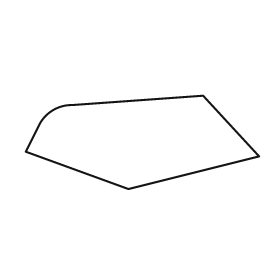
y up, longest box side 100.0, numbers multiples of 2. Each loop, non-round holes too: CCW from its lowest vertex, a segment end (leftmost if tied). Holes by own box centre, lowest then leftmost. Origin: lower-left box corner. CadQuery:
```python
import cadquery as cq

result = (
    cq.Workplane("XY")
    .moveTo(44.0, 0.0)
    .lineTo(100.0, 14.0)
    .lineTo(76.0, 40.0)
    .lineTo(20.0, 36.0)
    .threePointArc((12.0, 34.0), (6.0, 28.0))
    .lineTo(0.0, 16.0)
    .close()
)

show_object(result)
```